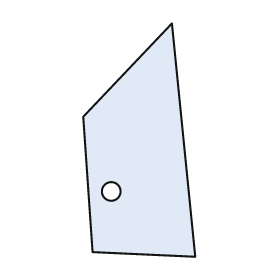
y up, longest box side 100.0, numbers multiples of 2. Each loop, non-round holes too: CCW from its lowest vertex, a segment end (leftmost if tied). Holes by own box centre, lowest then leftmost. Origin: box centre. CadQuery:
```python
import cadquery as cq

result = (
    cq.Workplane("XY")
    .moveTo(24.0, -50.0)
    .lineTo(14.0, 50.0)
    .lineTo(-24.0, 10.0)
    .lineTo(-20.0, -48.0)
    .close()
    .moveTo(-12.0, -22.0)
    .circle(4.0)
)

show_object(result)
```